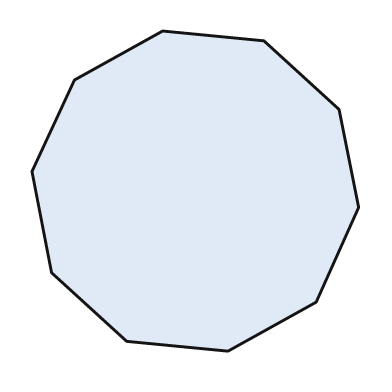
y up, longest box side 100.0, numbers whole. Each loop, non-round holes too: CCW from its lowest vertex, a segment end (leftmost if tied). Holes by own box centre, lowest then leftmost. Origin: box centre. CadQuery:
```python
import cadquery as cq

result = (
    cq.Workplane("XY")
    .moveTo(10.0, -49.0)
    .lineTo(37.0, -34.0)
    .lineTo(50.0, -5.0)
    .lineTo(44.0, 25.0)
    .lineTo(21.0, 46.0)
    .lineTo(-10.0, 49.0)
    .lineTo(-37.0, 34.0)
    .lineTo(-50.0, 6.0)
    .lineTo(-44.0, -25.0)
    .lineTo(-21.0, -46.0)
    .close()
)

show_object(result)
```